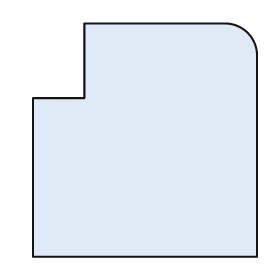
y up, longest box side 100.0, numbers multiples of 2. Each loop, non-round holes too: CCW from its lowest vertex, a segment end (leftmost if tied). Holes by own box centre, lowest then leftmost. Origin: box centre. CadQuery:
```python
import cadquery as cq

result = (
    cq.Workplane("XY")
    .moveTo(-48.0, -50.0)
    .lineTo(48.0, -50.0)
    .lineTo(48.0, 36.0)
    .threePointArc((44.0, 46.0), (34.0, 50.0))
    .lineTo(-26.0, 50.0)
    .lineTo(-26.0, 18.0)
    .lineTo(-48.0, 18.0)
    .close()
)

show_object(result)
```